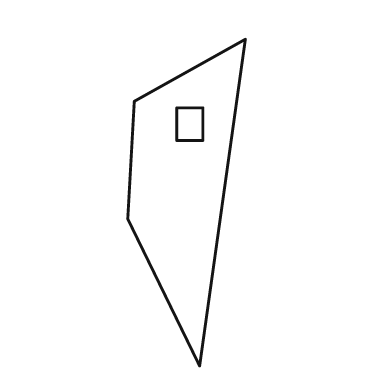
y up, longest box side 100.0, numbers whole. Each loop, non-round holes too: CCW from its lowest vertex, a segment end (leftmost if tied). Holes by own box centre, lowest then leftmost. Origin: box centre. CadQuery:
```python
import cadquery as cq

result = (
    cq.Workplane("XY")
    .moveTo(4.0, -50.0)
    .lineTo(18.0, 50.0)
    .lineTo(-16.0, 31.0)
    .lineTo(-18.0, -5.0)
    .close()
    .moveTo(-3.0, 19.0)
    .lineTo(5.0, 19.0)
    .lineTo(5.0, 29.0)
    .lineTo(-3.0, 29.0)
    .close()
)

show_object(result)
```